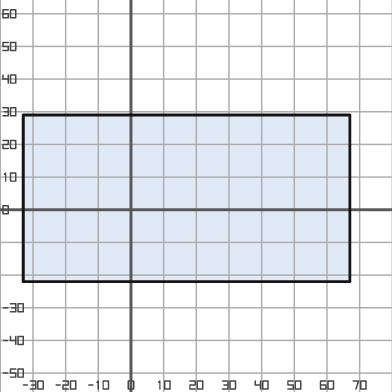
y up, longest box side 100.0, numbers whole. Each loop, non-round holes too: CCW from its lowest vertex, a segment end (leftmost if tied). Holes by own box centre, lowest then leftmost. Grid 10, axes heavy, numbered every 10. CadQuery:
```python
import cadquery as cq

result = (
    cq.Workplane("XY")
    .moveTo(-33.0, -22.0)
    .lineTo(67.0, -22.0)
    .lineTo(67.0, 29.0)
    .lineTo(-33.0, 29.0)
    .close()
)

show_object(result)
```